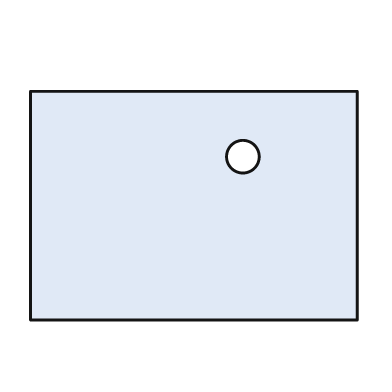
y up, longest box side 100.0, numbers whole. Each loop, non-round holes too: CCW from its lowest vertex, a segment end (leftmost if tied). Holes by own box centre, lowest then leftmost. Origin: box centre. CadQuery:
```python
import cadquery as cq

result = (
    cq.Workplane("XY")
    .moveTo(-50.0, -35.0)
    .lineTo(50.0, -35.0)
    .lineTo(50.0, 35.0)
    .lineTo(-50.0, 35.0)
    .close()
    .moveTo(15.0, 15.0)
    .circle(5.0)
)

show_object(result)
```